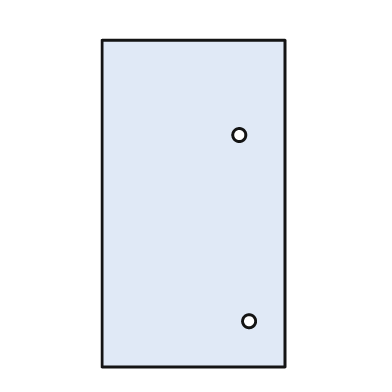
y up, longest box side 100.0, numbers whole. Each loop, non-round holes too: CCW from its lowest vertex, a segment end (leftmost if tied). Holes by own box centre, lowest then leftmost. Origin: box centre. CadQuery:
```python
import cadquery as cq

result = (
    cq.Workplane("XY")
    .moveTo(-28.0, -50.0)
    .lineTo(28.0, -50.0)
    .lineTo(28.0, 50.0)
    .lineTo(-28.0, 50.0)
    .close()
    .moveTo(17.0, -36.0)
    .circle(2.0)
    .moveTo(14.0, 21.0)
    .circle(2.0)
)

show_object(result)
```